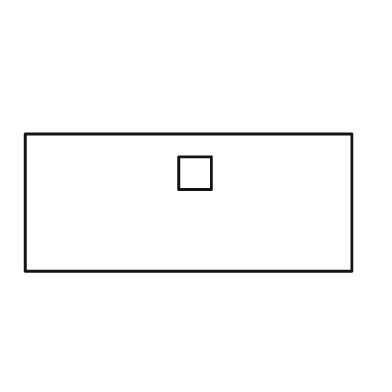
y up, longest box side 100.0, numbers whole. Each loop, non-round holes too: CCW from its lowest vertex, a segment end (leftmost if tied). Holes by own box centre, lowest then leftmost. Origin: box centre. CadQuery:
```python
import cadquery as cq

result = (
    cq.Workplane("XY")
    .moveTo(-50.0, -21.0)
    .lineTo(50.0, -21.0)
    .lineTo(50.0, 21.0)
    .lineTo(-50.0, 21.0)
    .close()
    .moveTo(-3.0, 4.0)
    .lineTo(7.0, 4.0)
    .lineTo(7.0, 14.0)
    .lineTo(-3.0, 14.0)
    .close()
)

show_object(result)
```